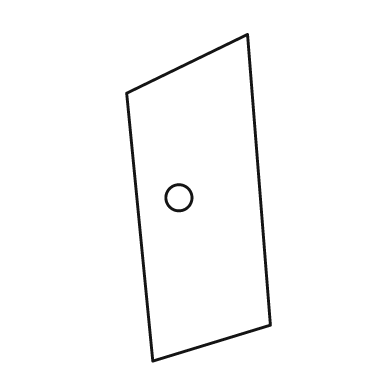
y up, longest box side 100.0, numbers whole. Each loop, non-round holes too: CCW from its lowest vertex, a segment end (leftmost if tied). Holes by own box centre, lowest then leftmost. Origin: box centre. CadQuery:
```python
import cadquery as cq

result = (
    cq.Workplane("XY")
    .moveTo(-14.0, -50.0)
    .lineTo(22.0, -39.0)
    .lineTo(15.0, 50.0)
    .lineTo(-22.0, 32.0)
    .close()
    .moveTo(-6.0, 0.0)
    .circle(4.0)
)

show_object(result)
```